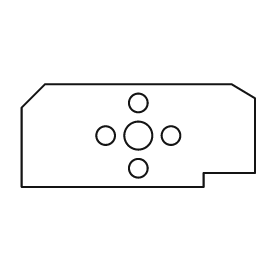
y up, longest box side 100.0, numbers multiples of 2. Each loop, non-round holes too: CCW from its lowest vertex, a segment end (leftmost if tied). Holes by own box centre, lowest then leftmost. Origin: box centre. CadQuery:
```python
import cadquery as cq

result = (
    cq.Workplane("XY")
    .moveTo(-50.0, -22.0)
    .lineTo(28.0, -22.0)
    .lineTo(28.0, -16.0)
    .lineTo(50.0, -16.0)
    .lineTo(50.0, 16.0)
    .lineTo(40.0, 22.0)
    .lineTo(-40.0, 22.0)
    .lineTo(-50.0, 12.0)
    .close()
    .moveTo(0.0, -14.0)
    .circle(4.0)
    .moveTo(-14.0, 0.0)
    .circle(4.0)
    .moveTo(0.0, 0.0)
    .circle(6.0)
    .moveTo(14.0, 0.0)
    .circle(4.0)
    .moveTo(0.0, 14.0)
    .circle(4.0)
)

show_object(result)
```